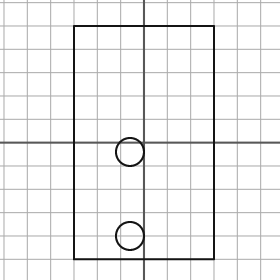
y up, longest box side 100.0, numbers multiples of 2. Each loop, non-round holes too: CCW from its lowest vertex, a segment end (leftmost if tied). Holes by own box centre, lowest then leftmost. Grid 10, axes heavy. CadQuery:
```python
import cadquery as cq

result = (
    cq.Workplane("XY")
    .moveTo(-30.0, -50.0)
    .lineTo(30.0, -50.0)
    .lineTo(30.0, 50.0)
    .lineTo(-30.0, 50.0)
    .close()
    .moveTo(-6.0, -40.0)
    .circle(6.0)
    .moveTo(-6.0, -4.0)
    .circle(6.0)
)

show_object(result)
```